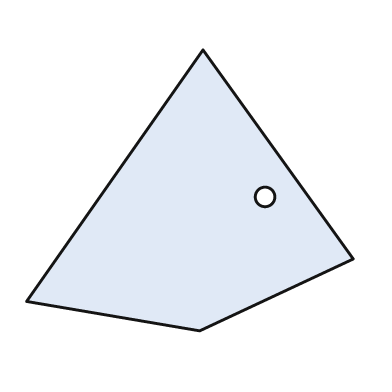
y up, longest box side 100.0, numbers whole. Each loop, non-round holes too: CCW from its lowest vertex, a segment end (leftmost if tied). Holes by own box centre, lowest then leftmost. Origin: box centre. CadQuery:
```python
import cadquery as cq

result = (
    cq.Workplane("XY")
    .moveTo(3.0, -43.0)
    .lineTo(50.0, -21.0)
    .lineTo(4.0, 43.0)
    .lineTo(-50.0, -34.0)
    .close()
    .moveTo(23.0, -2.0)
    .circle(3.0)
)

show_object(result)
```